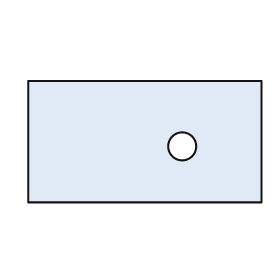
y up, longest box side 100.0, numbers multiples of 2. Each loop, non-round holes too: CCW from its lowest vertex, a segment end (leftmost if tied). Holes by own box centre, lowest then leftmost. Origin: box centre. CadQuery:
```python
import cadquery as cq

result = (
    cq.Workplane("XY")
    .moveTo(-50.0, -26.0)
    .lineTo(50.0, -26.0)
    .lineTo(50.0, 26.0)
    .lineTo(-50.0, 26.0)
    .close()
    .moveTo(16.0, -2.0)
    .circle(6.0)
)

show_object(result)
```